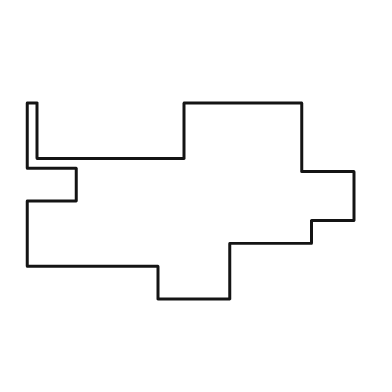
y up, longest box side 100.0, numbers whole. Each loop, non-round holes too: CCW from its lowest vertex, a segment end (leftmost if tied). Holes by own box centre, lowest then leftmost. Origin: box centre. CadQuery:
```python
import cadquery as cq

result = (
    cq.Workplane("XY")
    .moveTo(-10.0, -30.0)
    .lineTo(12.0, -30.0)
    .lineTo(12.0, -13.0)
    .lineTo(37.0, -13.0)
    .lineTo(37.0, -6.0)
    .lineTo(50.0, -6.0)
    .lineTo(50.0, 9.0)
    .lineTo(34.0, 9.0)
    .lineTo(34.0, 30.0)
    .lineTo(-2.0, 30.0)
    .lineTo(-2.0, 13.0)
    .lineTo(-47.0, 13.0)
    .lineTo(-47.0, 30.0)
    .lineTo(-50.0, 30.0)
    .lineTo(-50.0, 10.0)
    .lineTo(-35.0, 10.0)
    .lineTo(-35.0, 0.0)
    .lineTo(-50.0, 0.0)
    .lineTo(-50.0, -20.0)
    .lineTo(-10.0, -20.0)
    .close()
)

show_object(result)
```